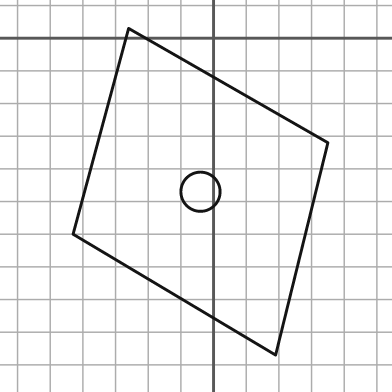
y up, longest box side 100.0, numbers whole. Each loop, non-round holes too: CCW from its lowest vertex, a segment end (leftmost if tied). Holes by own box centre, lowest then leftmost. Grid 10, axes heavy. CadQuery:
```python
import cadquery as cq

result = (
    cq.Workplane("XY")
    .moveTo(19.0, -97.0)
    .lineTo(35.0, -32.0)
    .lineTo(-26.0, 3.0)
    .lineTo(-43.0, -60.0)
    .close()
    .moveTo(-4.0, -47.0)
    .circle(6.0)
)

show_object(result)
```